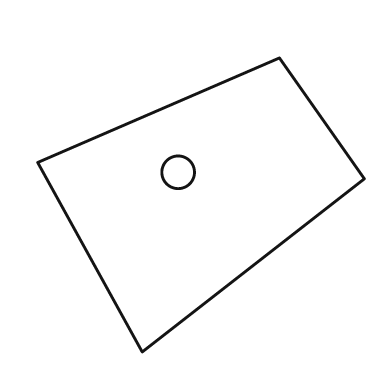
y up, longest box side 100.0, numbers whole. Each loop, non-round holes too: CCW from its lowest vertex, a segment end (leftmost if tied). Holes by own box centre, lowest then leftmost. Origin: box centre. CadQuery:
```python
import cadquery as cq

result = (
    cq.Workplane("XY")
    .moveTo(-18.0, -45.0)
    .lineTo(50.0, 8.0)
    .lineTo(24.0, 45.0)
    .lineTo(-50.0, 13.0)
    .close()
    .moveTo(-7.0, 10.0)
    .circle(5.0)
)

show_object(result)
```